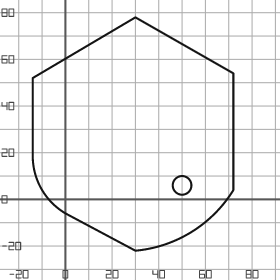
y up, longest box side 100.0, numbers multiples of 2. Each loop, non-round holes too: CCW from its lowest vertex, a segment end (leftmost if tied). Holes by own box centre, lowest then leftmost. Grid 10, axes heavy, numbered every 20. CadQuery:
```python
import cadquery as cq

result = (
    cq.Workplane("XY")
    .moveTo(30.0, -22.0)
    .threePointArc((54.0, -14.0), (72.0, 4.0))
    .lineTo(72.0, 54.0)
    .lineTo(30.0, 78.0)
    .lineTo(-14.0, 52.0)
    .lineTo(-14.0, 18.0)
    .threePointArc((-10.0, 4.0), (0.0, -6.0))
    .close()
    .moveTo(50.0, 6.0)
    .circle(4.0)
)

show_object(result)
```